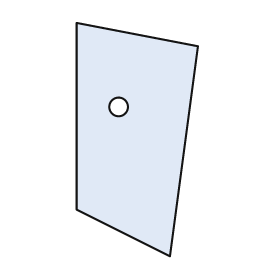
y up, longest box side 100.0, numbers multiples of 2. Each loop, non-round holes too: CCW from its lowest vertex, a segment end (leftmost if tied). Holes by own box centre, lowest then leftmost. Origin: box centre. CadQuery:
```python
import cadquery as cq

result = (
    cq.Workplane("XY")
    .moveTo(14.0, -50.0)
    .lineTo(26.0, 40.0)
    .lineTo(-26.0, 50.0)
    .lineTo(-26.0, -30.0)
    .close()
    .moveTo(-8.0, 14.0)
    .circle(4.0)
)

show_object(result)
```